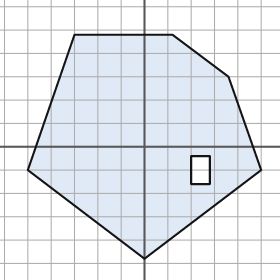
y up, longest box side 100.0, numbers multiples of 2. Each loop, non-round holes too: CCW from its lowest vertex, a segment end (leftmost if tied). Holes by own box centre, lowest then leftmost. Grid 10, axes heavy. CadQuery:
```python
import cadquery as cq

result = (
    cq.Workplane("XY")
    .moveTo(0.0, -48.0)
    .lineTo(50.0, -10.0)
    .lineTo(36.0, 30.0)
    .lineTo(12.0, 48.0)
    .lineTo(-30.0, 48.0)
    .lineTo(-50.0, -10.0)
    .close()
    .moveTo(20.0, -16.0)
    .lineTo(28.0, -16.0)
    .lineTo(28.0, -4.0)
    .lineTo(20.0, -4.0)
    .close()
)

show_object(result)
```